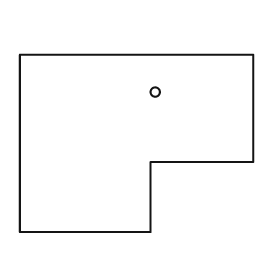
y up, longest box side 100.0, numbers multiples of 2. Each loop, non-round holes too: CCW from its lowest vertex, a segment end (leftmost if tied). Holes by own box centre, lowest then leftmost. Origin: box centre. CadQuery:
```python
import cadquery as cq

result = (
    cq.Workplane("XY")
    .moveTo(-50.0, -38.0)
    .lineTo(6.0, -38.0)
    .lineTo(6.0, -8.0)
    .lineTo(50.0, -8.0)
    .lineTo(50.0, 38.0)
    .lineTo(-50.0, 38.0)
    .close()
    .moveTo(8.0, 22.0)
    .circle(2.0)
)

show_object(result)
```